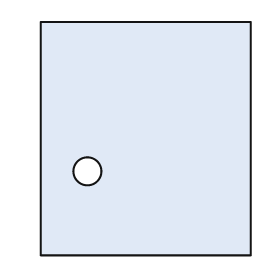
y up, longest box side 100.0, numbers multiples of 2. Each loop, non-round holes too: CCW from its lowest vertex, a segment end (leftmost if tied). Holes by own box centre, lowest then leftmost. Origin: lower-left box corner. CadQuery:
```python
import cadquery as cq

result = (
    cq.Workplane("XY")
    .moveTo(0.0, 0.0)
    .lineTo(90.0, 0.0)
    .lineTo(90.0, 100.0)
    .lineTo(0.0, 100.0)
    .close()
    .moveTo(20.0, 36.0)
    .circle(6.0)
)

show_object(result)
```